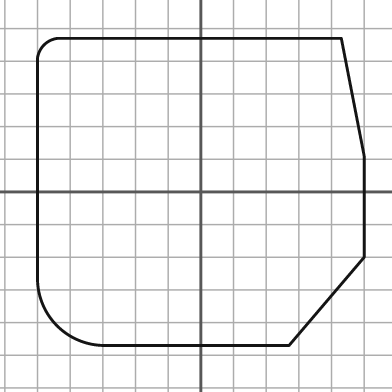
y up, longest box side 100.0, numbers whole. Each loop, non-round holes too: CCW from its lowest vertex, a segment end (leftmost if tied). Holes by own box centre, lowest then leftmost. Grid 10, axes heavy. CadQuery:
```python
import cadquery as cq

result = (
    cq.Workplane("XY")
    .moveTo(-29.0, -47.0)
    .lineTo(27.0, -47.0)
    .lineTo(50.0, -20.0)
    .lineTo(50.0, 11.0)
    .lineTo(43.0, 47.0)
    .lineTo(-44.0, 47.0)
    .threePointArc((-48.0, 45.0), (-50.0, 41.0))
    .lineTo(-50.0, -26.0)
    .threePointArc((-44.0, -41.0), (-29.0, -47.0))
    .close()
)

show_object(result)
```